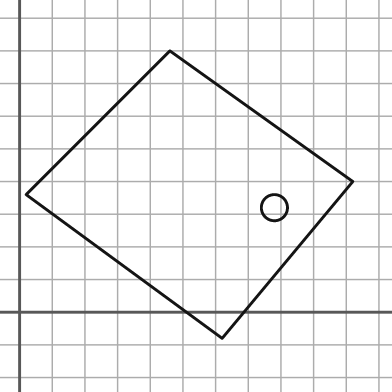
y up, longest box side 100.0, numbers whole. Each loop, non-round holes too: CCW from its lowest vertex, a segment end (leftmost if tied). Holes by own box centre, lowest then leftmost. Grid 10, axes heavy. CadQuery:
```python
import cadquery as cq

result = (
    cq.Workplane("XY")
    .moveTo(62.0, -8.0)
    .lineTo(102.0, 40.0)
    .lineTo(46.0, 80.0)
    .lineTo(2.0, 36.0)
    .close()
    .moveTo(78.0, 32.0)
    .circle(4.0)
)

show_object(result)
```